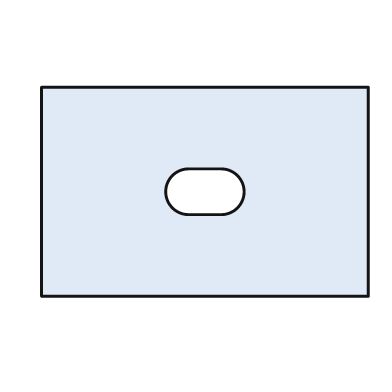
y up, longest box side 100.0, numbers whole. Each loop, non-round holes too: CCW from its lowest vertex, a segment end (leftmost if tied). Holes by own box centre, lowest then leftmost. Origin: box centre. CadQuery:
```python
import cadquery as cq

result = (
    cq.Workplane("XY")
    .moveTo(-50.0, -32.0)
    .lineTo(50.0, -32.0)
    .lineTo(50.0, 32.0)
    .lineTo(-50.0, 32.0)
    .close()
    .moveTo(-5.0, -7.0)
    .lineTo(5.0, -7.0)
    .threePointArc((12.0, 0.0), (5.0, 7.0))
    .lineTo(-5.0, 7.0)
    .threePointArc((-12.0, 0.0), (-5.0, -7.0))
    .close()
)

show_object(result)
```